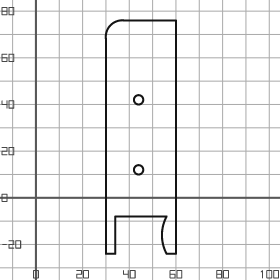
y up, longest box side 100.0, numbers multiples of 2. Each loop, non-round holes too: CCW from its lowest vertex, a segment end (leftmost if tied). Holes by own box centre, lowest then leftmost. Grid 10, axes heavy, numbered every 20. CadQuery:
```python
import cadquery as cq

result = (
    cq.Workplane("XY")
    .moveTo(30.0, -24.0)
    .lineTo(34.0, -24.0)
    .lineTo(34.0, -8.0)
    .lineTo(56.0, -8.0)
    .threePointArc((54.0, -16.0), (56.0, -24.0))
    .lineTo(60.0, -24.0)
    .lineTo(60.0, 76.0)
    .lineTo(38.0, 76.0)
    .threePointArc((32.0, 74.0), (30.0, 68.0))
    .close()
    .moveTo(44.0, 12.0)
    .circle(2.0)
    .moveTo(44.0, 42.0)
    .circle(2.0)
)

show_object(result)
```